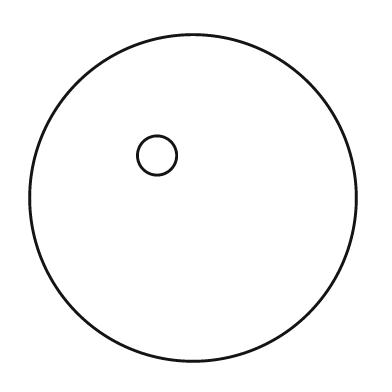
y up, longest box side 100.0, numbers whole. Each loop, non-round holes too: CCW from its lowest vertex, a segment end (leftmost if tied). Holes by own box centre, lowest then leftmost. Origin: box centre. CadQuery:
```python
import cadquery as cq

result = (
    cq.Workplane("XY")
    .moveTo(0.0, 0.0)
    .circle(50.0)
    .moveTo(-11.0, 13.0)
    .circle(6.0)
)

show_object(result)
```